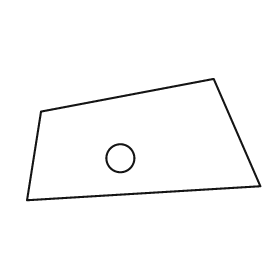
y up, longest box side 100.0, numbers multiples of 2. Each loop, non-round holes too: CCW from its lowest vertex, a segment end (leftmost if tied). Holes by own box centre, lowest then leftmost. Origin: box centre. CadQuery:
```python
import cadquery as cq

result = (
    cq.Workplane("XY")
    .moveTo(-50.0, -26.0)
    .lineTo(50.0, -20.0)
    .lineTo(30.0, 26.0)
    .lineTo(-44.0, 12.0)
    .close()
    .moveTo(-10.0, -8.0)
    .circle(6.0)
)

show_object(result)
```